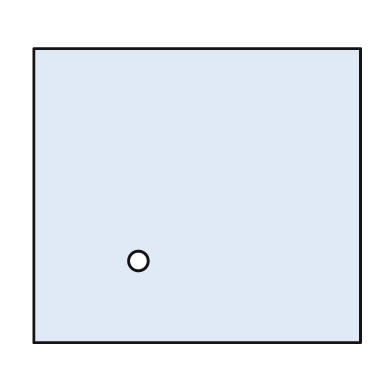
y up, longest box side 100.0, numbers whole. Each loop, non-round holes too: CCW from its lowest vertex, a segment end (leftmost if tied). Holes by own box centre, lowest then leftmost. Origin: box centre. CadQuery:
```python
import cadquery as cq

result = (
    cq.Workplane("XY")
    .moveTo(-50.0, -45.0)
    .lineTo(50.0, -45.0)
    .lineTo(50.0, 45.0)
    .lineTo(-50.0, 45.0)
    .close()
    .moveTo(-18.0, -20.0)
    .circle(3.0)
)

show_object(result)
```